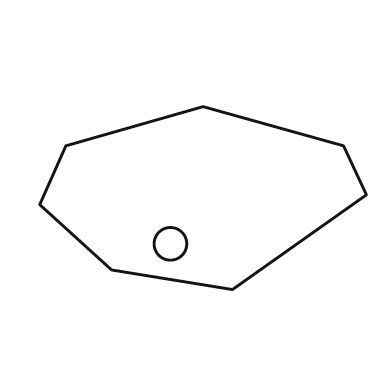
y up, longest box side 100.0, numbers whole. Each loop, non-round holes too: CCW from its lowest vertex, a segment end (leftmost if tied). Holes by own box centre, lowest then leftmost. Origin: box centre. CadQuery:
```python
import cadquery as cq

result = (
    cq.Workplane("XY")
    .moveTo(9.0, -28.0)
    .lineTo(50.0, 1.0)
    .lineTo(43.0, 16.0)
    .lineTo(0.0, 28.0)
    .lineTo(-42.0, 16.0)
    .lineTo(-50.0, -2.0)
    .lineTo(-28.0, -22.0)
    .close()
    .moveTo(-10.0, -14.0)
    .circle(5.0)
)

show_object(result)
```